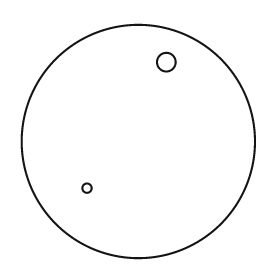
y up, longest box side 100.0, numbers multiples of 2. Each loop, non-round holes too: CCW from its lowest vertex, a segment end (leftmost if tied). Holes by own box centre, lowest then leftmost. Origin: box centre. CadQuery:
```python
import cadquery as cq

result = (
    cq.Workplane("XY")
    .moveTo(0.0, 0.0)
    .circle(50.0)
    .moveTo(-22.0, -20.0)
    .circle(2.0)
    .moveTo(12.0, 34.0)
    .circle(4.0)
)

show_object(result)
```